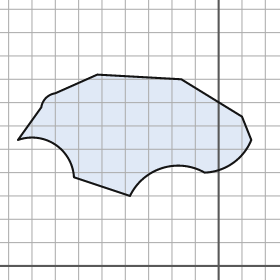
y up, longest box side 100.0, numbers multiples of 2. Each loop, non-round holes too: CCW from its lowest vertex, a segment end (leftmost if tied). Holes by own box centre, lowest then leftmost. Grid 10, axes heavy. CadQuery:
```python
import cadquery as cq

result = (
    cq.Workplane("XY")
    .moveTo(-38.0, 30.0)
    .threePointArc((-24.0, 42.0), (-6.0, 40.0))
    .threePointArc((6.0, 44.0), (14.0, 54.0))
    .lineTo(10.0, 64.0)
    .lineTo(-16.0, 80.0)
    .lineTo(-52.0, 82.0)
    .lineTo(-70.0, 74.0)
    .threePointArc((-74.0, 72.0), (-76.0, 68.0))
    .lineTo(-86.0, 54.0)
    .threePointArc((-70.0, 52.0), (-62.0, 38.0))
    .close()
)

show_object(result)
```